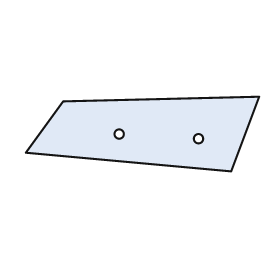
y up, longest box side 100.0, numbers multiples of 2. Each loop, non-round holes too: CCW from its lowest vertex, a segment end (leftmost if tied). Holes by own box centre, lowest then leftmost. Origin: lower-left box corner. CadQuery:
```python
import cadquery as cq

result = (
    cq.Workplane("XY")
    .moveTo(88.0, 0.0)
    .lineTo(100.0, 32.0)
    .lineTo(16.0, 30.0)
    .lineTo(0.0, 8.0)
    .close()
    .moveTo(74.0, 14.0)
    .circle(2.0)
    .moveTo(40.0, 16.0)
    .circle(2.0)
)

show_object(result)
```